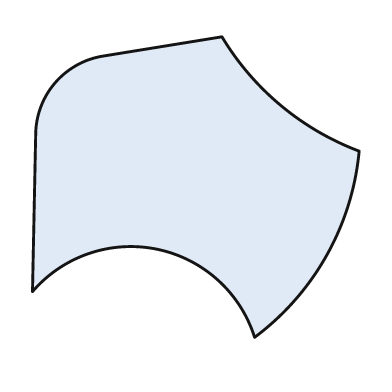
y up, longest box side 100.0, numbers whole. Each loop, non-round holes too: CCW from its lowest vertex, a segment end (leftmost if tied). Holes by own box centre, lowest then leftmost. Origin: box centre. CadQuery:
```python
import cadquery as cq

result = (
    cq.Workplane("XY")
    .moveTo(18.0, -46.0)
    .threePointArc((40.0, -21.0), (50.0, 11.0))
    .threePointArc((26.0, 25.0), (8.0, 46.0))
    .lineTo(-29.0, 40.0)
    .threePointArc((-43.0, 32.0), (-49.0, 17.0))
    .lineTo(-50.0, -32.0)
    .threePointArc((-12.0, -19.0), (18.0, -46.0))
    .close()
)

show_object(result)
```